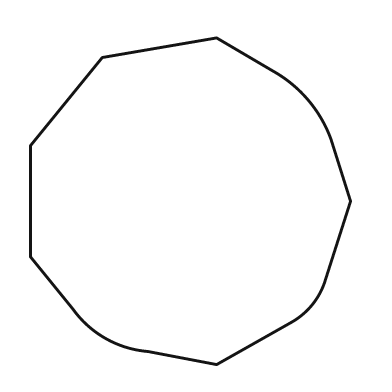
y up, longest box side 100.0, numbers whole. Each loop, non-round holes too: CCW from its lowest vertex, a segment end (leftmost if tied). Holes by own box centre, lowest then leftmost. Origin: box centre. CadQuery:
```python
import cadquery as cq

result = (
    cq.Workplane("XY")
    .moveTo(8.0, -50.0)
    .lineTo(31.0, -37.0)
    .threePointArc((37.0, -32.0), (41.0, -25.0))
    .lineTo(49.0, 0.0)
    .lineTo(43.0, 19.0)
    .threePointArc((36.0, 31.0), (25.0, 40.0))
    .lineTo(8.0, 50.0)
    .lineTo(-27.0, 44.0)
    .lineTo(-49.0, 17.0)
    .lineTo(-49.0, -17.0)
    .lineTo(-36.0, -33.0)
    .threePointArc((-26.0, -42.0), (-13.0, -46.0))
    .close()
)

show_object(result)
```